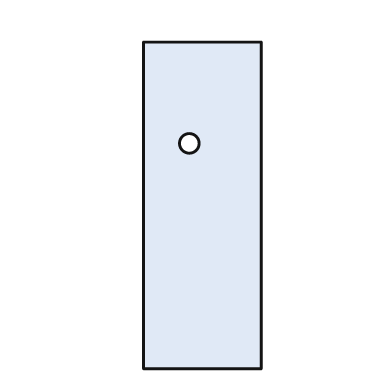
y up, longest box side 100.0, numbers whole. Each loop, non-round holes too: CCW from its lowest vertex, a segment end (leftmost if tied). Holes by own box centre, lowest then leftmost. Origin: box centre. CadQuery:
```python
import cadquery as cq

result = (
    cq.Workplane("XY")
    .moveTo(-18.0, -50.0)
    .lineTo(18.0, -50.0)
    .lineTo(18.0, 50.0)
    .lineTo(-18.0, 50.0)
    .close()
    .moveTo(-4.0, 19.0)
    .circle(3.0)
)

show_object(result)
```